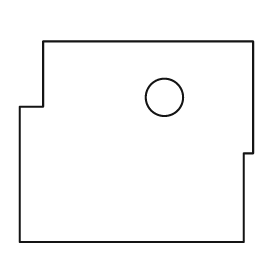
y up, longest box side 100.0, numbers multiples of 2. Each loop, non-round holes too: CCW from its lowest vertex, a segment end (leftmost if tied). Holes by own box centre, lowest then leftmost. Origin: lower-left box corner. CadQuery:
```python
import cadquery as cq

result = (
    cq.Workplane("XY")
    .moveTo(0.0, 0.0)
    .lineTo(96.0, 0.0)
    .lineTo(96.0, 38.0)
    .lineTo(100.0, 38.0)
    .lineTo(100.0, 86.0)
    .lineTo(10.0, 86.0)
    .lineTo(10.0, 58.0)
    .lineTo(0.0, 58.0)
    .close()
    .moveTo(62.0, 62.0)
    .circle(8.0)
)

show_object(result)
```